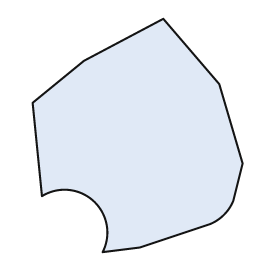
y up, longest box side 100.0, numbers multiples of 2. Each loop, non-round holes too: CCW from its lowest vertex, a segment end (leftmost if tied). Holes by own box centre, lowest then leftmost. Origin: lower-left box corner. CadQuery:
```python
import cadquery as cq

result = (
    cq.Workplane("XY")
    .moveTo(30.0, 0.0)
    .lineTo(46.0, 2.0)
    .lineTo(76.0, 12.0)
    .threePointArc((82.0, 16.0), (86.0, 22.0))
    .lineTo(90.0, 38.0)
    .lineTo(80.0, 72.0)
    .lineTo(56.0, 100.0)
    .lineTo(22.0, 82.0)
    .lineTo(0.0, 64.0)
    .lineTo(4.0, 24.0)
    .threePointArc((26.0, 22.0), (30.0, 0.0))
    .close()
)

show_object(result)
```